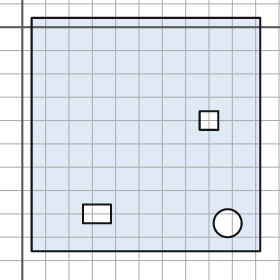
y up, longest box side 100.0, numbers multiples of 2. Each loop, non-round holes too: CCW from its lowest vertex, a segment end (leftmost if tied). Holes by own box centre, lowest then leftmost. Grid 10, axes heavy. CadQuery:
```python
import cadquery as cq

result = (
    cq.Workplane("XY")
    .moveTo(4.0, -96.0)
    .lineTo(102.0, -96.0)
    .lineTo(102.0, 4.0)
    .lineTo(4.0, 4.0)
    .close()
    .moveTo(88.0, -84.0)
    .circle(6.0)
    .moveTo(26.0, -84.0)
    .lineTo(38.0, -84.0)
    .lineTo(38.0, -76.0)
    .lineTo(26.0, -76.0)
    .close()
    .moveTo(76.0, -44.0)
    .lineTo(84.0, -44.0)
    .lineTo(84.0, -36.0)
    .lineTo(76.0, -36.0)
    .close()
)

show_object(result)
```